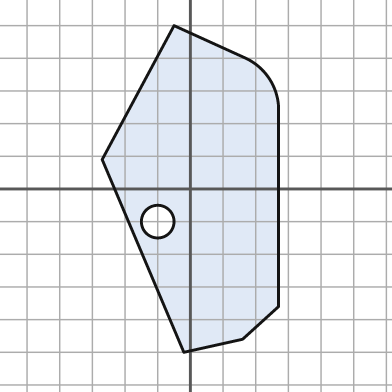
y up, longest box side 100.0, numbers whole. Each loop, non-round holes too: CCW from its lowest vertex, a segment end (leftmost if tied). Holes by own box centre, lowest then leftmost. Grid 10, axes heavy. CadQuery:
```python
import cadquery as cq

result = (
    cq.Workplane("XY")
    .moveTo(-2.0, -50.0)
    .lineTo(16.0, -46.0)
    .lineTo(27.0, -36.0)
    .lineTo(27.0, 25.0)
    .threePointArc((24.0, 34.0), (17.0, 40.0))
    .lineTo(-5.0, 50.0)
    .lineTo(-27.0, 9.0)
    .close()
    .moveTo(-10.0, -10.0)
    .circle(5.0)
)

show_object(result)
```